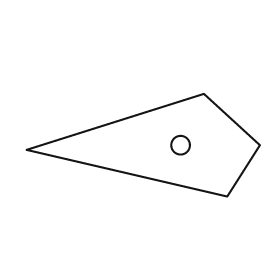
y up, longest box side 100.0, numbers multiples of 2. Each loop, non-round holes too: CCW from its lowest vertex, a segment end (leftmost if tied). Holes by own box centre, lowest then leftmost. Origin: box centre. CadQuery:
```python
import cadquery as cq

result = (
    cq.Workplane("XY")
    .moveTo(36.0, -22.0)
    .lineTo(50.0, 0.0)
    .lineTo(26.0, 22.0)
    .lineTo(-50.0, -2.0)
    .close()
    .moveTo(16.0, 0.0)
    .circle(4.0)
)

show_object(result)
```